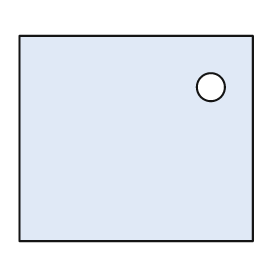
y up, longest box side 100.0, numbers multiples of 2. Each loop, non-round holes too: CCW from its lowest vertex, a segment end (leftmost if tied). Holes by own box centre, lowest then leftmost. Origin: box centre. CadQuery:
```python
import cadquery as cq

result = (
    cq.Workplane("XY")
    .moveTo(-50.0, -44.0)
    .lineTo(50.0, -44.0)
    .lineTo(50.0, 44.0)
    .lineTo(-50.0, 44.0)
    .close()
    .moveTo(32.0, 22.0)
    .circle(6.0)
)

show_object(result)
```